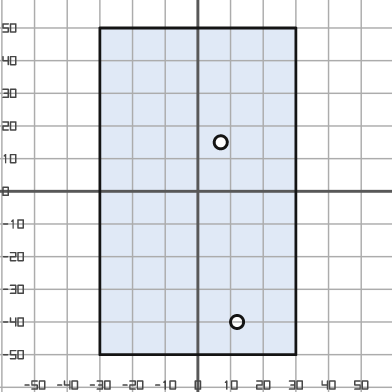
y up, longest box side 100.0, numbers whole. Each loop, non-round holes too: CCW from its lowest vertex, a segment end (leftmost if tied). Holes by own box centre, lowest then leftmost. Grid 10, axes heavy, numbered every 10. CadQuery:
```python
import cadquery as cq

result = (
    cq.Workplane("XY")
    .moveTo(-30.0, -50.0)
    .lineTo(30.0, -50.0)
    .lineTo(30.0, 50.0)
    .lineTo(-30.0, 50.0)
    .close()
    .moveTo(12.0, -40.0)
    .circle(2.0)
    .moveTo(7.0, 15.0)
    .circle(2.0)
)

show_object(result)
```